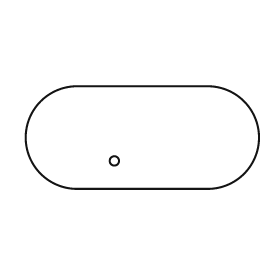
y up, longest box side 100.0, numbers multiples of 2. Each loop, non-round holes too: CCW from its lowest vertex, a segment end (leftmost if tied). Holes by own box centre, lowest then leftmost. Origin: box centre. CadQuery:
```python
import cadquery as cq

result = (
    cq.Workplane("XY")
    .moveTo(-28.0, -22.0)
    .lineTo(28.0, -22.0)
    .threePointArc((50.0, 0.0), (28.0, 22.0))
    .lineTo(-28.0, 22.0)
    .threePointArc((-50.0, 0.0), (-28.0, -22.0))
    .close()
    .moveTo(-12.0, -10.0)
    .circle(2.0)
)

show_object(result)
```